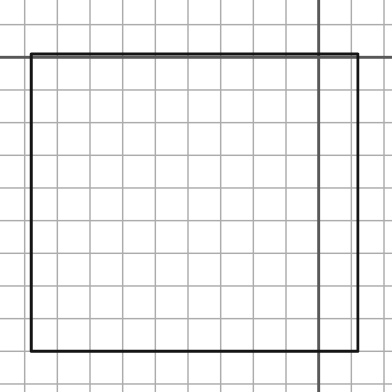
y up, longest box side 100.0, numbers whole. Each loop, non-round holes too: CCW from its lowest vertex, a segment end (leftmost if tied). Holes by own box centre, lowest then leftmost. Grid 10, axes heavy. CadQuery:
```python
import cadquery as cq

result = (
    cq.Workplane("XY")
    .moveTo(-88.0, -90.0)
    .lineTo(12.0, -90.0)
    .lineTo(12.0, 1.0)
    .lineTo(-88.0, 1.0)
    .close()
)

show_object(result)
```